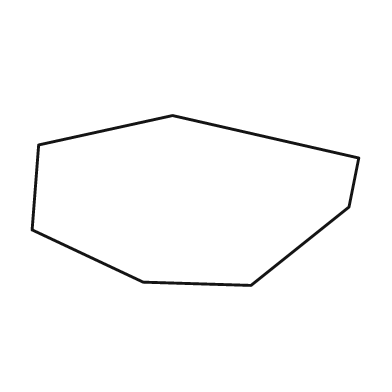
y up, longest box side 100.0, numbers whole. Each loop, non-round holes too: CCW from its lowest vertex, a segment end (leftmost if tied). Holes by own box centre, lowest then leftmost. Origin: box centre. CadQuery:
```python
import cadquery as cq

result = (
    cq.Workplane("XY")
    .moveTo(17.0, -26.0)
    .lineTo(47.0, -2.0)
    .lineTo(50.0, 13.0)
    .lineTo(-7.0, 26.0)
    .lineTo(-48.0, 17.0)
    .lineTo(-50.0, -9.0)
    .lineTo(-16.0, -25.0)
    .close()
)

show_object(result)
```